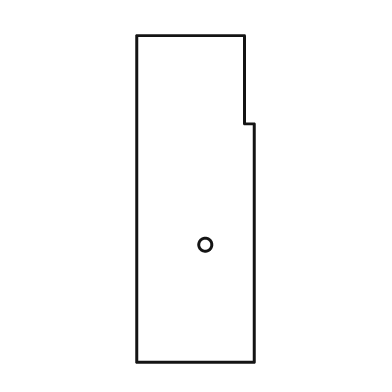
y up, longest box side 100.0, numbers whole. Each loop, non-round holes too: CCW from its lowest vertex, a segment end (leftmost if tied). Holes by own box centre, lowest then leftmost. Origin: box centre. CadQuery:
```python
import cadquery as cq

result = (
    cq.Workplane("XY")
    .moveTo(-18.0, -50.0)
    .lineTo(18.0, -50.0)
    .lineTo(18.0, 23.0)
    .lineTo(15.0, 23.0)
    .lineTo(15.0, 50.0)
    .lineTo(-18.0, 50.0)
    .close()
    .moveTo(3.0, -14.0)
    .circle(2.0)
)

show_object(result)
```